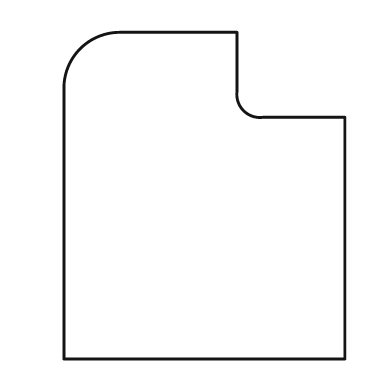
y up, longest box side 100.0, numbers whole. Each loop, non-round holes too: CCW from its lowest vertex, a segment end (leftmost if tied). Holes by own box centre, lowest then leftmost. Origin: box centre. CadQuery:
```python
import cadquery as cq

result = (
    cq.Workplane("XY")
    .moveTo(-43.0, -50.0)
    .lineTo(43.0, -50.0)
    .lineTo(43.0, 24.0)
    .lineTo(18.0, 24.0)
    .threePointArc((12.0, 26.0), (10.0, 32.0))
    .lineTo(10.0, 50.0)
    .lineTo(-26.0, 50.0)
    .threePointArc((-38.0, 45.0), (-43.0, 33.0))
    .close()
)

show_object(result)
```